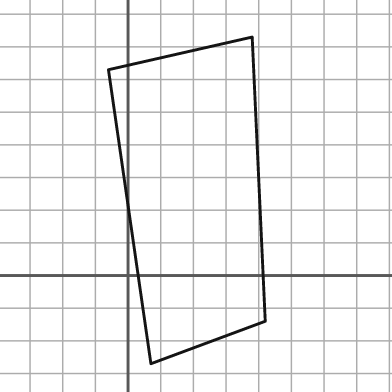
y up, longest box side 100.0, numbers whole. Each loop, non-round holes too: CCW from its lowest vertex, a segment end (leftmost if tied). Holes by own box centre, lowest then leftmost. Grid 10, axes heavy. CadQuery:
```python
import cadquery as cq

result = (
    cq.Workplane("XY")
    .moveTo(7.0, -27.0)
    .lineTo(42.0, -14.0)
    .lineTo(38.0, 73.0)
    .lineTo(-6.0, 63.0)
    .close()
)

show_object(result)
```